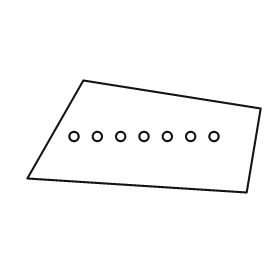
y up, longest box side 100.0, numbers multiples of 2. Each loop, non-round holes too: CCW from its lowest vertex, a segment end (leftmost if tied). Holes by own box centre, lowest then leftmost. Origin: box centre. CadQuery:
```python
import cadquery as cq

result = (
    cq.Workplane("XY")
    .moveTo(44.0, -24.0)
    .lineTo(50.0, 12.0)
    .lineTo(-26.0, 24.0)
    .lineTo(-50.0, -18.0)
    .close()
    .moveTo(-30.0, 0.0)
    .circle(2.0)
    .moveTo(-20.0, 0.0)
    .circle(2.0)
    .moveTo(-10.0, 0.0)
    .circle(2.0)
    .moveTo(0.0, 0.0)
    .circle(2.0)
    .moveTo(10.0, 0.0)
    .circle(2.0)
    .moveTo(20.0, 0.0)
    .circle(2.0)
    .moveTo(30.0, 0.0)
    .circle(2.0)
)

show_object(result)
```